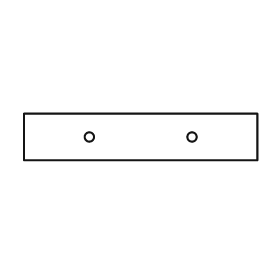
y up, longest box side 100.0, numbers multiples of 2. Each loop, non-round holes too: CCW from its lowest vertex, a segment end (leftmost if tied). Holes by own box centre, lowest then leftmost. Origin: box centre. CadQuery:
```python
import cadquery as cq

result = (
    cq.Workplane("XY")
    .moveTo(-50.0, -10.0)
    .lineTo(50.0, -10.0)
    .lineTo(50.0, 10.0)
    .lineTo(-50.0, 10.0)
    .close()
    .moveTo(-22.0, 0.0)
    .circle(2.0)
    .moveTo(22.0, 0.0)
    .circle(2.0)
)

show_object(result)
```